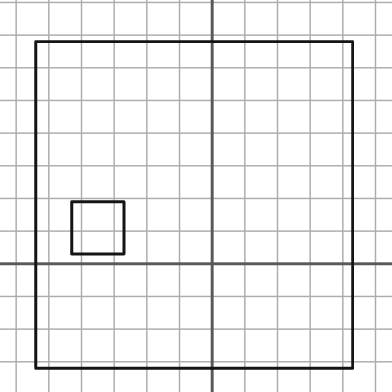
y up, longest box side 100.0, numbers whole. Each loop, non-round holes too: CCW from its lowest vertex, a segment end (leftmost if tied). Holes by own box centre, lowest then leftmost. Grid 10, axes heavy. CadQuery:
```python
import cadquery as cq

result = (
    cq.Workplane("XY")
    .moveTo(-54.0, -32.0)
    .lineTo(43.0, -32.0)
    .lineTo(43.0, 68.0)
    .lineTo(-54.0, 68.0)
    .close()
    .moveTo(-43.0, 3.0)
    .lineTo(-27.0, 3.0)
    .lineTo(-27.0, 19.0)
    .lineTo(-43.0, 19.0)
    .close()
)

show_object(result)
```